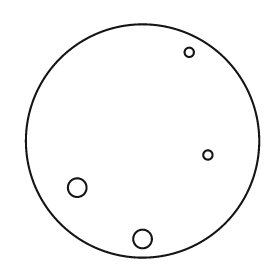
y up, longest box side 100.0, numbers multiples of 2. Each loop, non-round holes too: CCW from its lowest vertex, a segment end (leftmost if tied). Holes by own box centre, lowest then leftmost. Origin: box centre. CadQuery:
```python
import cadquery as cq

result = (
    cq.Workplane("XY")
    .moveTo(0.0, 0.0)
    .circle(50.0)
    .moveTo(0.0, -42.0)
    .circle(4.0)
    .moveTo(-28.0, -20.0)
    .circle(4.0)
    .moveTo(28.0, -6.0)
    .circle(2.0)
    .moveTo(20.0, 38.0)
    .circle(2.0)
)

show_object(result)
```